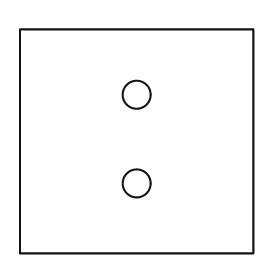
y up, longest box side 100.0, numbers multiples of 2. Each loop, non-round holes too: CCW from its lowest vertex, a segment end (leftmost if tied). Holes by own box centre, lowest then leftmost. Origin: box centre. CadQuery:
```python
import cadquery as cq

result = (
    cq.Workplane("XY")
    .moveTo(-50.0, -48.0)
    .lineTo(50.0, -48.0)
    .lineTo(50.0, 48.0)
    .lineTo(-50.0, 48.0)
    .close()
    .moveTo(0.0, -18.0)
    .circle(6.0)
    .moveTo(0.0, 20.0)
    .circle(6.0)
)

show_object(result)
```